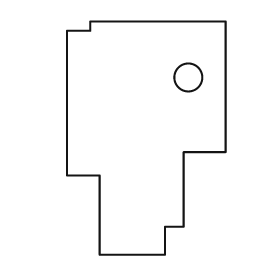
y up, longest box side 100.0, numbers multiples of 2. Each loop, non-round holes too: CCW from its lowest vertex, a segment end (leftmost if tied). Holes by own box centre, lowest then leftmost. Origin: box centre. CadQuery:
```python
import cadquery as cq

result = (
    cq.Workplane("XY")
    .moveTo(-20.0, -50.0)
    .lineTo(8.0, -50.0)
    .lineTo(8.0, -38.0)
    .lineTo(16.0, -38.0)
    .lineTo(16.0, -6.0)
    .lineTo(34.0, -6.0)
    .lineTo(34.0, 50.0)
    .lineTo(-24.0, 50.0)
    .lineTo(-24.0, 46.0)
    .lineTo(-34.0, 46.0)
    .lineTo(-34.0, -16.0)
    .lineTo(-20.0, -16.0)
    .close()
    .moveTo(18.0, 26.0)
    .circle(6.0)
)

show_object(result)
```